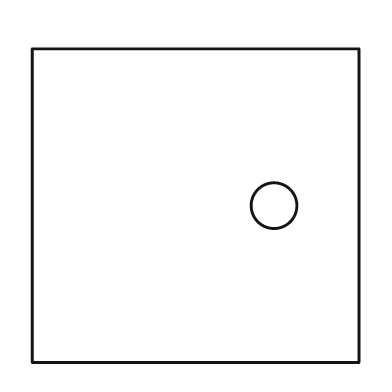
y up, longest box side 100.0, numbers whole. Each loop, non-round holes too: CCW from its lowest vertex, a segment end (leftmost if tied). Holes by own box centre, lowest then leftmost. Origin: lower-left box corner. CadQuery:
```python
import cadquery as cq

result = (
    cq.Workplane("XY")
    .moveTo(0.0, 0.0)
    .lineTo(100.0, 0.0)
    .lineTo(100.0, 96.0)
    .lineTo(0.0, 96.0)
    .close()
    .moveTo(74.0, 48.0)
    .circle(7.0)
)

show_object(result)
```